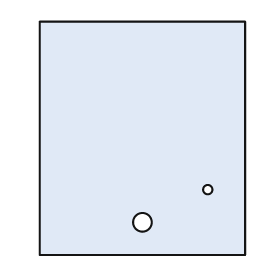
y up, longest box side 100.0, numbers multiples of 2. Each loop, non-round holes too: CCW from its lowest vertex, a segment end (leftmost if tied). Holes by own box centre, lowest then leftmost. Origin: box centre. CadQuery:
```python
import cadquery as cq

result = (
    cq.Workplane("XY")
    .moveTo(-44.0, -50.0)
    .lineTo(44.0, -50.0)
    .lineTo(44.0, 50.0)
    .lineTo(-44.0, 50.0)
    .close()
    .moveTo(0.0, -36.0)
    .circle(4.0)
    .moveTo(28.0, -22.0)
    .circle(2.0)
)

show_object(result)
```